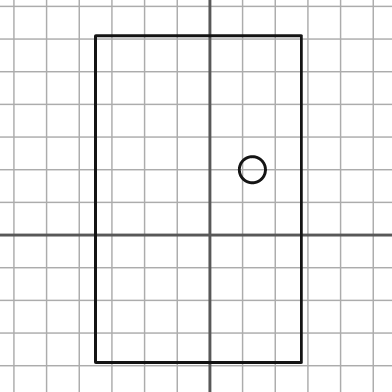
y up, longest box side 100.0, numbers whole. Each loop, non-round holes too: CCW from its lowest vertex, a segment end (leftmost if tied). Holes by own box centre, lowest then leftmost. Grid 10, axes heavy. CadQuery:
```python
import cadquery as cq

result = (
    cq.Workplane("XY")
    .moveTo(-35.0, -39.0)
    .lineTo(28.0, -39.0)
    .lineTo(28.0, 61.0)
    .lineTo(-35.0, 61.0)
    .close()
    .moveTo(13.0, 20.0)
    .circle(4.0)
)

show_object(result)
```